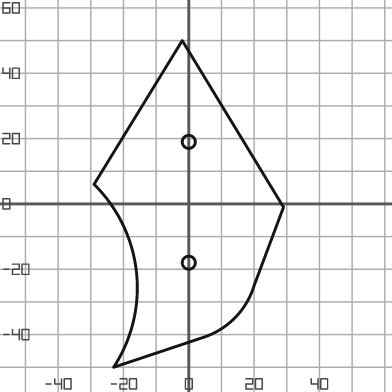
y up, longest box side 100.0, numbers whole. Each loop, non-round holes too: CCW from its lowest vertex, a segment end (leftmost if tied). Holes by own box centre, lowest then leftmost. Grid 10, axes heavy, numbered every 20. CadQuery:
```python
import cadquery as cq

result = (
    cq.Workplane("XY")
    .moveTo(-23.0, -50.0)
    .lineTo(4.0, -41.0)
    .threePointArc((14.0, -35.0), (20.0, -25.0))
    .lineTo(29.0, -1.0)
    .lineTo(-2.0, 50.0)
    .lineTo(-29.0, 6.0)
    .threePointArc((-16.0, -21.0), (-23.0, -50.0))
    .close()
    .moveTo(0.0, -18.0)
    .circle(2.0)
    .moveTo(0.0, 19.0)
    .circle(2.0)
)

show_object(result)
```